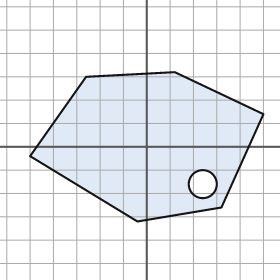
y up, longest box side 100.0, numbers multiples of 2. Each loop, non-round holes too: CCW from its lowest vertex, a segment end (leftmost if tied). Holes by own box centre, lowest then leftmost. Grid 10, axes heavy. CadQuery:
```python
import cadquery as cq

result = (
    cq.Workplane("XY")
    .moveTo(-4.0, -32.0)
    .lineTo(32.0, -26.0)
    .lineTo(50.0, 14.0)
    .lineTo(12.0, 32.0)
    .lineTo(-26.0, 30.0)
    .lineTo(-50.0, -4.0)
    .close()
    .moveTo(24.0, -16.0)
    .circle(6.0)
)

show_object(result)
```